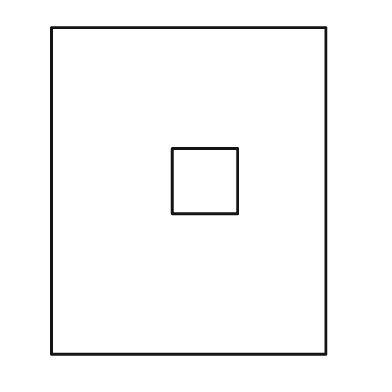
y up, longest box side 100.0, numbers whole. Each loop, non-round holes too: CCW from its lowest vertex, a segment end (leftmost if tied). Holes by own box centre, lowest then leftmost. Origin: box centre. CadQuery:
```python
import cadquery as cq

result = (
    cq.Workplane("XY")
    .moveTo(-42.0, -50.0)
    .lineTo(42.0, -50.0)
    .lineTo(42.0, 50.0)
    .lineTo(-42.0, 50.0)
    .close()
    .moveTo(-5.0, -7.0)
    .lineTo(15.0, -7.0)
    .lineTo(15.0, 13.0)
    .lineTo(-5.0, 13.0)
    .close()
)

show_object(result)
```